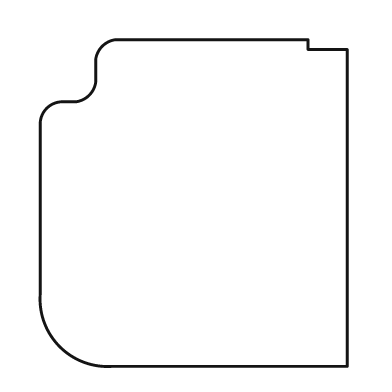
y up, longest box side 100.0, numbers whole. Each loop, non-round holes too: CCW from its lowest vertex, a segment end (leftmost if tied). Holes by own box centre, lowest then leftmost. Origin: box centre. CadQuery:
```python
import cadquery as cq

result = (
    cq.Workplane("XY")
    .moveTo(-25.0, -50.0)
    .lineTo(47.0, -50.0)
    .lineTo(47.0, 47.0)
    .lineTo(35.0, 47.0)
    .lineTo(35.0, 50.0)
    .lineTo(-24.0, 50.0)
    .threePointArc((-28.0, 48.0), (-30.0, 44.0))
    .lineTo(-30.0, 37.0)
    .threePointArc((-32.0, 33.0), (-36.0, 31.0))
    .lineTo(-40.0, 31.0)
    .threePointArc((-45.0, 29.0), (-47.0, 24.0))
    .lineTo(-47.0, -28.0)
    .threePointArc((-41.0, -44.0), (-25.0, -50.0))
    .close()
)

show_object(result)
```